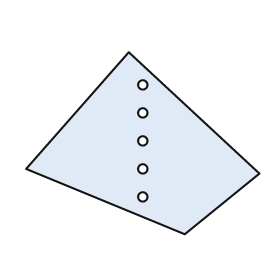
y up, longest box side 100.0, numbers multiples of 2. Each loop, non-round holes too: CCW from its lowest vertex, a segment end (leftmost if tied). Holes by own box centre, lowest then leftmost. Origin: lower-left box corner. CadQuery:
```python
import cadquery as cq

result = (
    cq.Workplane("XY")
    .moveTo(68.0, 0.0)
    .lineTo(100.0, 26.0)
    .lineTo(44.0, 78.0)
    .lineTo(0.0, 28.0)
    .close()
    .moveTo(50.0, 16.0)
    .circle(2.0)
    .moveTo(50.0, 28.0)
    .circle(2.0)
    .moveTo(50.0, 40.0)
    .circle(2.0)
    .moveTo(50.0, 52.0)
    .circle(2.0)
    .moveTo(50.0, 64.0)
    .circle(2.0)
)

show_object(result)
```